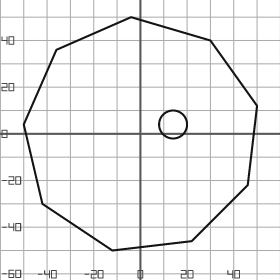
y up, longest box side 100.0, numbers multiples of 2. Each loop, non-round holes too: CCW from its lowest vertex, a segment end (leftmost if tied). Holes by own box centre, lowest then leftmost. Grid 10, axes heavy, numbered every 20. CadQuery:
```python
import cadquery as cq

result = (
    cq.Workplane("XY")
    .moveTo(-12.0, -50.0)
    .lineTo(22.0, -46.0)
    .lineTo(46.0, -22.0)
    .lineTo(50.0, 12.0)
    .lineTo(30.0, 40.0)
    .lineTo(-4.0, 50.0)
    .lineTo(-36.0, 36.0)
    .lineTo(-50.0, 4.0)
    .lineTo(-42.0, -30.0)
    .close()
    .moveTo(14.0, 4.0)
    .circle(6.0)
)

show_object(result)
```